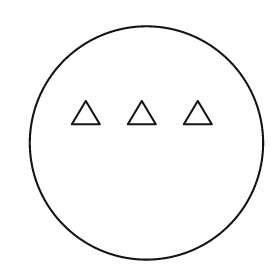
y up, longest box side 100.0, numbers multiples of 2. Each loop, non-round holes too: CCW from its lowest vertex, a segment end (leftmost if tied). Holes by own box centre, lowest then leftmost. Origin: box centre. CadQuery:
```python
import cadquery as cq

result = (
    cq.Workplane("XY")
    .moveTo(0.0, 0.0)
    .circle(50.0)
    .moveTo(-32.0, 8.0)
    .lineTo(-20.0, 8.0)
    .lineTo(-26.0, 18.0)
    .close()
    .moveTo(-8.0, 8.0)
    .lineTo(4.0, 8.0)
    .lineTo(-2.0, 18.0)
    .close()
    .moveTo(16.0, 8.0)
    .lineTo(28.0, 8.0)
    .lineTo(22.0, 18.0)
    .close()
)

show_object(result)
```